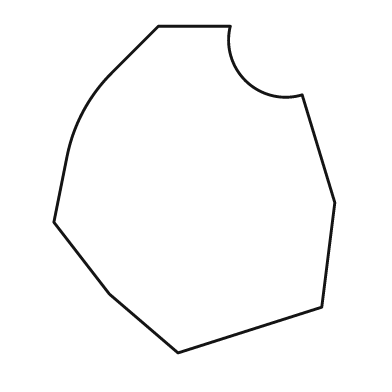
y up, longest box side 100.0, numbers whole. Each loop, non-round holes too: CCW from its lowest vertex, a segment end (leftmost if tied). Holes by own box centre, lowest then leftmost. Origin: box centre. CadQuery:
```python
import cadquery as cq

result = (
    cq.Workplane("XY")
    .moveTo(-5.0, -50.0)
    .lineTo(39.0, -36.0)
    .lineTo(43.0, -4.0)
    .lineTo(33.0, 29.0)
    .threePointArc((16.0, 33.0), (11.0, 50.0))
    .lineTo(-11.0, 50.0)
    .lineTo(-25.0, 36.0)
    .threePointArc((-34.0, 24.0), (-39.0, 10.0))
    .lineTo(-43.0, -10.0)
    .lineTo(-26.0, -32.0)
    .close()
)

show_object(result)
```